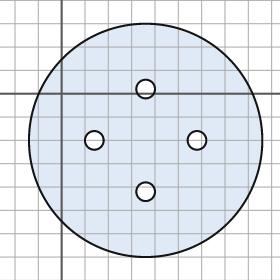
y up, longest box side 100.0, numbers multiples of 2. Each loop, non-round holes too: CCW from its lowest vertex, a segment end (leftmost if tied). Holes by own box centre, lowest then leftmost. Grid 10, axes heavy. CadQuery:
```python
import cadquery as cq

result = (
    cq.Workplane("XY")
    .moveTo(36.0, -20.0)
    .circle(50.0)
    .moveTo(36.0, -42.0)
    .circle(4.0)
    .moveTo(14.0, -20.0)
    .circle(4.0)
    .moveTo(58.0, -20.0)
    .circle(4.0)
    .moveTo(36.0, 2.0)
    .circle(4.0)
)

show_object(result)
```